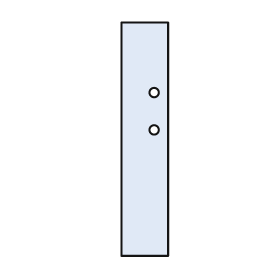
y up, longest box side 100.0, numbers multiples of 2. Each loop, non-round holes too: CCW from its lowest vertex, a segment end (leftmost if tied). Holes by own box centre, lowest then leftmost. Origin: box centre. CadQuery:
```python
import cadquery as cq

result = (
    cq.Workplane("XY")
    .moveTo(-10.0, -50.0)
    .lineTo(10.0, -50.0)
    .lineTo(10.0, 50.0)
    .lineTo(-10.0, 50.0)
    .close()
    .moveTo(4.0, 4.0)
    .circle(2.0)
    .moveTo(4.0, 20.0)
    .circle(2.0)
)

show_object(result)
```